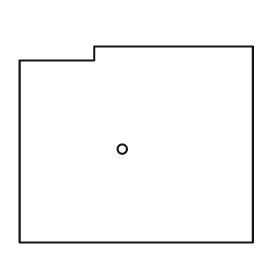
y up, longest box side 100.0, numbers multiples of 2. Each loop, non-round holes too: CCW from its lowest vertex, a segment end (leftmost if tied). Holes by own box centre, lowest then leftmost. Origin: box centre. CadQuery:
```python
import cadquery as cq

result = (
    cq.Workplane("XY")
    .moveTo(-50.0, -42.0)
    .lineTo(50.0, -42.0)
    .lineTo(50.0, 42.0)
    .lineTo(-18.0, 42.0)
    .lineTo(-18.0, 36.0)
    .lineTo(-50.0, 36.0)
    .close()
    .moveTo(-6.0, -2.0)
    .circle(2.0)
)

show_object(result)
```